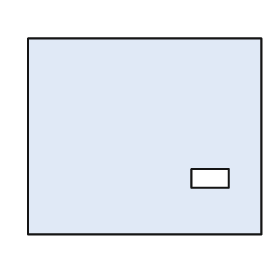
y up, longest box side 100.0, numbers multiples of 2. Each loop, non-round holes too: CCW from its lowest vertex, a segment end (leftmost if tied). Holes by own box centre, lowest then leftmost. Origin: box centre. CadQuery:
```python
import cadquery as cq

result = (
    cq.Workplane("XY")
    .moveTo(-50.0, -42.0)
    .lineTo(50.0, -42.0)
    .lineTo(50.0, 42.0)
    .lineTo(-50.0, 42.0)
    .close()
    .moveTo(20.0, -22.0)
    .lineTo(36.0, -22.0)
    .lineTo(36.0, -14.0)
    .lineTo(20.0, -14.0)
    .close()
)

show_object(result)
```